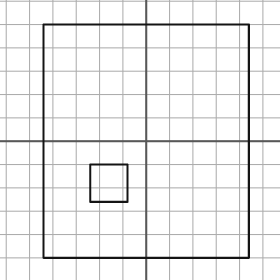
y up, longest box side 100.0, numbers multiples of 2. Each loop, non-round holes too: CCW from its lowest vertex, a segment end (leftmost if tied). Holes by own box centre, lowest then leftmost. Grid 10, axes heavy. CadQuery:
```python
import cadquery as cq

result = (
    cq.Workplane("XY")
    .moveTo(-44.0, -50.0)
    .lineTo(44.0, -50.0)
    .lineTo(44.0, 50.0)
    .lineTo(-44.0, 50.0)
    .close()
    .moveTo(-24.0, -26.0)
    .lineTo(-8.0, -26.0)
    .lineTo(-8.0, -10.0)
    .lineTo(-24.0, -10.0)
    .close()
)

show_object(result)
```